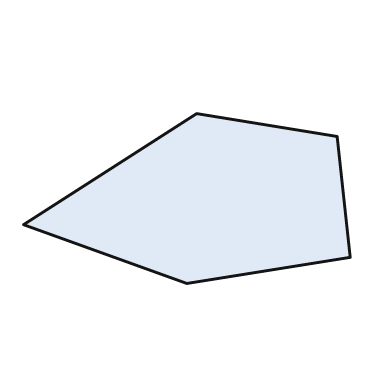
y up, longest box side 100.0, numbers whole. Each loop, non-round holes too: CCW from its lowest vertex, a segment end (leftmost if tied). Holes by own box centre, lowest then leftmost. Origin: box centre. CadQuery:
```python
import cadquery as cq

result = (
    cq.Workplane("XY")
    .moveTo(0.0, -26.0)
    .lineTo(50.0, -18.0)
    .lineTo(46.0, 19.0)
    .lineTo(3.0, 26.0)
    .lineTo(-50.0, -8.0)
    .close()
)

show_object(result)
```